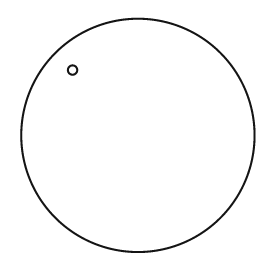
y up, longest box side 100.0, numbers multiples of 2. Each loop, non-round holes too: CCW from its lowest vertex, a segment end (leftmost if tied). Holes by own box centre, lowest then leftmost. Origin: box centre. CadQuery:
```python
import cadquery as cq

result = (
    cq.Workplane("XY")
    .moveTo(0.0, 0.0)
    .circle(50.0)
    .moveTo(-28.0, 28.0)
    .circle(2.0)
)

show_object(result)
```